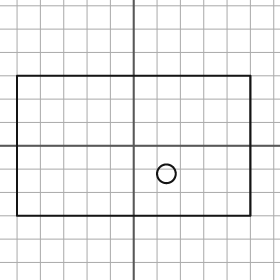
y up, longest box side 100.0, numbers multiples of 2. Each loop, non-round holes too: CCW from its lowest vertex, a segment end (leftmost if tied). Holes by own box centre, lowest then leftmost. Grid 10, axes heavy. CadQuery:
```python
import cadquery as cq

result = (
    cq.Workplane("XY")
    .moveTo(-50.0, -30.0)
    .lineTo(50.0, -30.0)
    .lineTo(50.0, 30.0)
    .lineTo(-50.0, 30.0)
    .close()
    .moveTo(14.0, -12.0)
    .circle(4.0)
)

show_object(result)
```